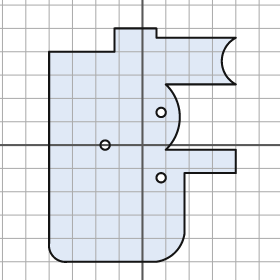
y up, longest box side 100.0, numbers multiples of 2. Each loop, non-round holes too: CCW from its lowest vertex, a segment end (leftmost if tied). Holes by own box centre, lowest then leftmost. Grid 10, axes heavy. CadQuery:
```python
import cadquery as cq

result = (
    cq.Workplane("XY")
    .moveTo(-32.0, -50.0)
    .lineTo(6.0, -50.0)
    .threePointArc((14.0, -46.0), (18.0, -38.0))
    .lineTo(18.0, -12.0)
    .lineTo(40.0, -12.0)
    .lineTo(40.0, -2.0)
    .lineTo(10.0, -2.0)
    .threePointArc((16.0, 12.0), (10.0, 26.0))
    .lineTo(40.0, 26.0)
    .threePointArc((34.0, 36.0), (40.0, 46.0))
    .lineTo(6.0, 46.0)
    .lineTo(6.0, 50.0)
    .lineTo(-12.0, 50.0)
    .lineTo(-12.0, 40.0)
    .lineTo(-40.0, 40.0)
    .lineTo(-40.0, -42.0)
    .threePointArc((-38.0, -48.0), (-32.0, -50.0))
    .close()
    .moveTo(8.0, -14.0)
    .circle(2.0)
    .moveTo(-16.0, 0.0)
    .circle(2.0)
    .moveTo(8.0, 14.0)
    .circle(2.0)
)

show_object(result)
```